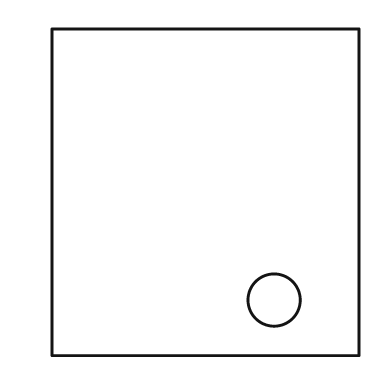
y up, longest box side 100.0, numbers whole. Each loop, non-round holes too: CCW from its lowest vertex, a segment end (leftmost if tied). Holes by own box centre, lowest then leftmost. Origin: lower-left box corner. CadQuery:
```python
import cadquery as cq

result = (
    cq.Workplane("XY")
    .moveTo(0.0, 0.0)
    .lineTo(94.0, 0.0)
    .lineTo(94.0, 100.0)
    .lineTo(0.0, 100.0)
    .close()
    .moveTo(68.0, 17.0)
    .circle(8.0)
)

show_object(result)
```